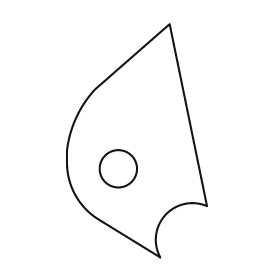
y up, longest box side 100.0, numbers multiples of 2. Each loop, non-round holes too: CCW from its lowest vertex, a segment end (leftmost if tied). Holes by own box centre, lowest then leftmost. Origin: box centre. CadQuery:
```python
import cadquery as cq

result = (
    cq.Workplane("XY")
    .moveTo(10.0, -50.0)
    .threePointArc((12.0, -32.0), (30.0, -28.0))
    .lineTo(14.0, 50.0)
    .lineTo(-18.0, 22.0)
    .threePointArc((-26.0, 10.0), (-30.0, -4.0))
    .lineTo(-30.0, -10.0)
    .threePointArc((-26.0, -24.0), (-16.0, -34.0))
    .close()
    .moveTo(-8.0, -12.0)
    .circle(8.0)
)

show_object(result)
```